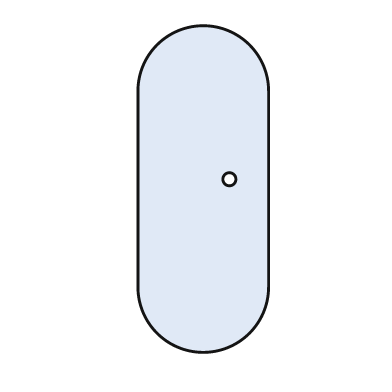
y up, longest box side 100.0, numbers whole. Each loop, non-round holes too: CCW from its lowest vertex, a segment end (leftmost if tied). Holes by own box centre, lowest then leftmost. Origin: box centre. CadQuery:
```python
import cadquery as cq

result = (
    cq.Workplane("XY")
    .moveTo(-20.0, -30.0)
    .threePointArc((0.0, -50.0), (20.0, -30.0))
    .lineTo(20.0, 30.0)
    .threePointArc((0.0, 50.0), (-20.0, 30.0))
    .close()
    .moveTo(8.0, 3.0)
    .circle(2.0)
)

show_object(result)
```